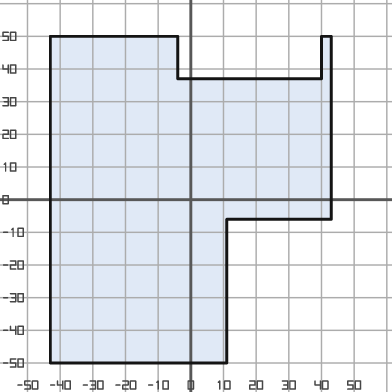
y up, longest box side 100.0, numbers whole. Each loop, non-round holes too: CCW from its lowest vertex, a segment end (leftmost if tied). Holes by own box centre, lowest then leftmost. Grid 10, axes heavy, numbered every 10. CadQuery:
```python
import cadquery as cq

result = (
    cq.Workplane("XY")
    .moveTo(-43.0, -50.0)
    .lineTo(11.0, -50.0)
    .lineTo(11.0, -6.0)
    .lineTo(43.0, -6.0)
    .lineTo(43.0, 50.0)
    .lineTo(40.0, 50.0)
    .lineTo(40.0, 37.0)
    .lineTo(-4.0, 37.0)
    .lineTo(-4.0, 50.0)
    .lineTo(-43.0, 50.0)
    .close()
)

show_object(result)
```